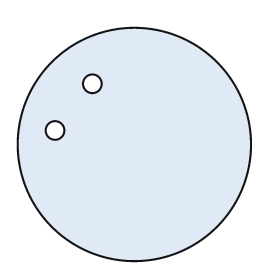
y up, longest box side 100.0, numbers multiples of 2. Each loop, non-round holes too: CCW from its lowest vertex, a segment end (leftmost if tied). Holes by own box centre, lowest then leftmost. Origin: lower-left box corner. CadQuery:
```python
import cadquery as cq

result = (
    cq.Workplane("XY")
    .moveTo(50.0, 50.0)
    .circle(50.0)
    .moveTo(16.0, 56.0)
    .circle(4.0)
    .moveTo(32.0, 76.0)
    .circle(4.0)
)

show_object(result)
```